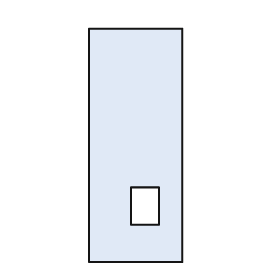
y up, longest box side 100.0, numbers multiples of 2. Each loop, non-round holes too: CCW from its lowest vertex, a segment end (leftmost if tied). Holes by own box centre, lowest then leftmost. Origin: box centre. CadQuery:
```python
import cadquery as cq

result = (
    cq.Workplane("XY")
    .moveTo(-20.0, -50.0)
    .lineTo(20.0, -50.0)
    .lineTo(20.0, 50.0)
    .lineTo(-20.0, 50.0)
    .close()
    .moveTo(-2.0, -34.0)
    .lineTo(10.0, -34.0)
    .lineTo(10.0, -18.0)
    .lineTo(-2.0, -18.0)
    .close()
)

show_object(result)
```